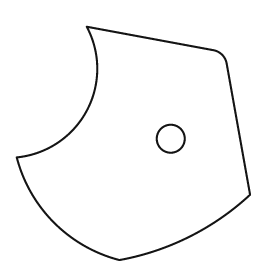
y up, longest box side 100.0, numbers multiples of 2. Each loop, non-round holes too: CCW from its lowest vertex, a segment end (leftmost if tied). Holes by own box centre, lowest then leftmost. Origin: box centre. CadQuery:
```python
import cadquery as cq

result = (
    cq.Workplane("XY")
    .moveTo(-6.0, -50.0)
    .threePointArc((24.0, -40.0), (50.0, -22.0))
    .lineTo(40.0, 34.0)
    .threePointArc((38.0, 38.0), (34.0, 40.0))
    .lineTo(-20.0, 50.0)
    .threePointArc((-20.0, 14.0), (-50.0, -6.0))
    .threePointArc((-34.0, -34.0), (-6.0, -50.0))
    .close()
    .moveTo(16.0, 2.0)
    .circle(6.0)
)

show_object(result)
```